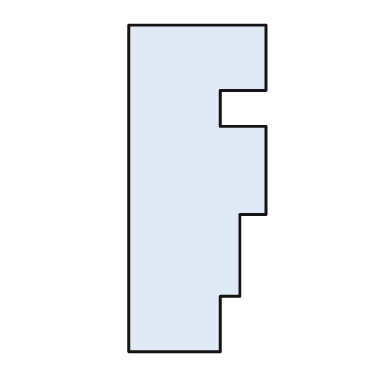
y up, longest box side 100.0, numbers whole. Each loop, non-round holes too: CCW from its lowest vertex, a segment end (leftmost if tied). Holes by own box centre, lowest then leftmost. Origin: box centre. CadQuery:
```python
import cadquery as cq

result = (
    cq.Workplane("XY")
    .moveTo(-21.0, -50.0)
    .lineTo(7.0, -50.0)
    .lineTo(7.0, -33.0)
    .lineTo(13.0, -33.0)
    .lineTo(13.0, -8.0)
    .lineTo(21.0, -8.0)
    .lineTo(21.0, 19.0)
    .lineTo(7.0, 19.0)
    .lineTo(7.0, 30.0)
    .lineTo(21.0, 30.0)
    .lineTo(21.0, 50.0)
    .lineTo(-21.0, 50.0)
    .close()
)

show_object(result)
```